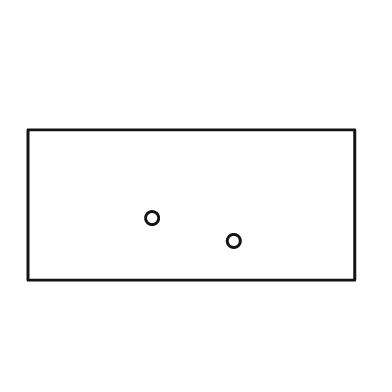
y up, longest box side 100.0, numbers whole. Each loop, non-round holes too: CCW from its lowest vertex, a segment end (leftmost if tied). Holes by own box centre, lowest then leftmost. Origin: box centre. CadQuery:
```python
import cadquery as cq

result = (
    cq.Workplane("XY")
    .moveTo(-50.0, -23.0)
    .lineTo(50.0, -23.0)
    .lineTo(50.0, 23.0)
    .lineTo(-50.0, 23.0)
    .close()
    .moveTo(13.0, -11.0)
    .circle(2.0)
    .moveTo(-12.0, -4.0)
    .circle(2.0)
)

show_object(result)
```